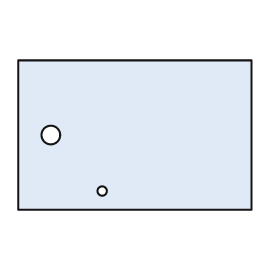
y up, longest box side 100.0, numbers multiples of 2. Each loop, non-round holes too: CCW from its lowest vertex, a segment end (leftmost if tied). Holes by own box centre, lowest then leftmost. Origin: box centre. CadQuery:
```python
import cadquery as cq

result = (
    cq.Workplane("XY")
    .moveTo(-50.0, -32.0)
    .lineTo(50.0, -32.0)
    .lineTo(50.0, 32.0)
    .lineTo(-50.0, 32.0)
    .close()
    .moveTo(-14.0, -24.0)
    .circle(2.0)
    .moveTo(-36.0, 0.0)
    .circle(4.0)
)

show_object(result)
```